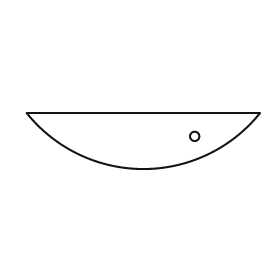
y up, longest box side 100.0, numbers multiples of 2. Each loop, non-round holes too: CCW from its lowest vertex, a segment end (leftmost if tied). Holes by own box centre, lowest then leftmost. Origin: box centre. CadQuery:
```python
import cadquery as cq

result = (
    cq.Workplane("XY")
    .moveTo(-50.0, 12.0)
    .threePointArc((0.0, -12.0), (50.0, 12.0))
    .close()
    .moveTo(22.0, 2.0)
    .circle(2.0)
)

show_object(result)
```